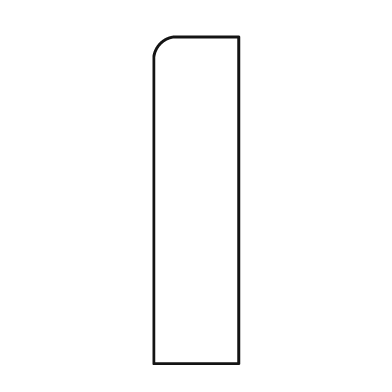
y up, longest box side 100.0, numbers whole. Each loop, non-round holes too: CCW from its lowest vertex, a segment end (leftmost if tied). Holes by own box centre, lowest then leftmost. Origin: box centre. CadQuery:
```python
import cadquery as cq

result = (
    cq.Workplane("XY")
    .moveTo(-13.0, -50.0)
    .lineTo(13.0, -50.0)
    .lineTo(13.0, 50.0)
    .lineTo(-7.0, 50.0)
    .threePointArc((-11.0, 48.0), (-13.0, 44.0))
    .close()
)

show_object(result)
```